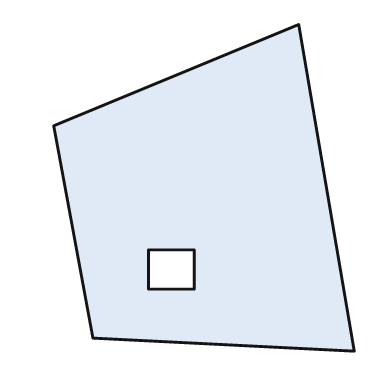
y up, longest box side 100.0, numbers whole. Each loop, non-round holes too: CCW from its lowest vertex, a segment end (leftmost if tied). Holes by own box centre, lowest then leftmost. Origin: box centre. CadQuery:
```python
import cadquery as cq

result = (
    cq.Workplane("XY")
    .moveTo(46.0, -50.0)
    .lineTo(29.0, 50.0)
    .lineTo(-46.0, 19.0)
    .lineTo(-34.0, -46.0)
    .close()
    .moveTo(-17.0, -31.0)
    .lineTo(-3.0, -31.0)
    .lineTo(-3.0, -19.0)
    .lineTo(-17.0, -19.0)
    .close()
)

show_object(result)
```